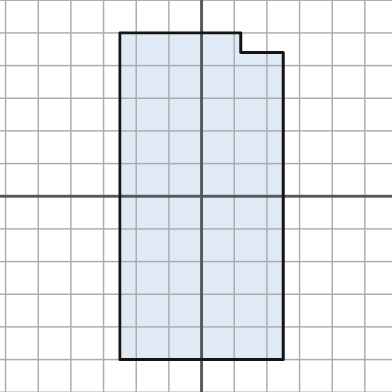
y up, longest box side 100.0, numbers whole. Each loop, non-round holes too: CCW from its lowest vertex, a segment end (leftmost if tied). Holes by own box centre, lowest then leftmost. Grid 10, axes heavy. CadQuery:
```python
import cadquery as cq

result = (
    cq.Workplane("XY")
    .moveTo(-25.0, -50.0)
    .lineTo(25.0, -50.0)
    .lineTo(25.0, 44.0)
    .lineTo(12.0, 44.0)
    .lineTo(12.0, 50.0)
    .lineTo(-25.0, 50.0)
    .close()
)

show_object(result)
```